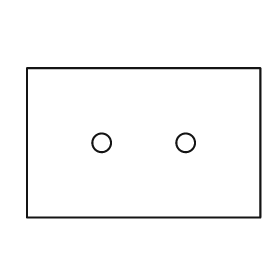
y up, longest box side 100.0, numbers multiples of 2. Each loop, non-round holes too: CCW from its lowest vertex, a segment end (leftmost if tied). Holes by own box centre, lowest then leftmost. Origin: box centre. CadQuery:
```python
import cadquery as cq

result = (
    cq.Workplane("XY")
    .moveTo(-50.0, -32.0)
    .lineTo(50.0, -32.0)
    .lineTo(50.0, 32.0)
    .lineTo(-50.0, 32.0)
    .close()
    .moveTo(-18.0, 0.0)
    .circle(4.0)
    .moveTo(18.0, 0.0)
    .circle(4.0)
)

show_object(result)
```